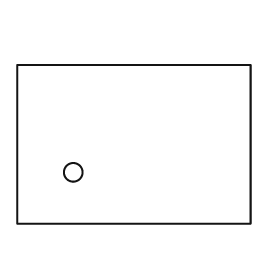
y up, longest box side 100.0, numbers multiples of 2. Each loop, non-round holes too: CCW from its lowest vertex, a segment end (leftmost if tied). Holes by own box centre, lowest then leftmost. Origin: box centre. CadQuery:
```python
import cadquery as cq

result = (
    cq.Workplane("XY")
    .moveTo(-50.0, -34.0)
    .lineTo(50.0, -34.0)
    .lineTo(50.0, 34.0)
    .lineTo(-50.0, 34.0)
    .close()
    .moveTo(-26.0, -12.0)
    .circle(4.0)
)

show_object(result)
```